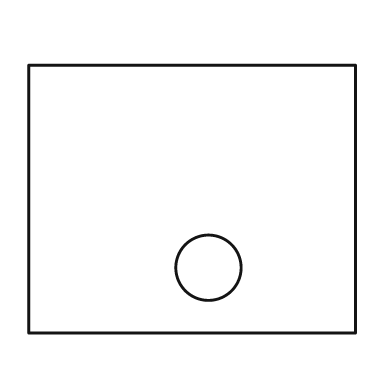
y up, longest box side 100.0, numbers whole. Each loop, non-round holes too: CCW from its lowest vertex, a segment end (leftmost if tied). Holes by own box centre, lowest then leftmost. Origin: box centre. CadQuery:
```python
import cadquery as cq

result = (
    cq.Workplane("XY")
    .moveTo(-50.0, -41.0)
    .lineTo(50.0, -41.0)
    .lineTo(50.0, 41.0)
    .lineTo(-50.0, 41.0)
    .close()
    .moveTo(5.0, -21.0)
    .circle(10.0)
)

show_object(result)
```